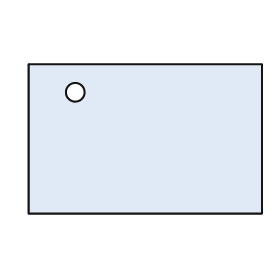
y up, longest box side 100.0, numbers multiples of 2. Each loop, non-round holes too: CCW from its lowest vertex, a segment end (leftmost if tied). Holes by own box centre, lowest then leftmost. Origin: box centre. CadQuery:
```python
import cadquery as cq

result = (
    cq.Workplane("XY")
    .moveTo(-50.0, -32.0)
    .lineTo(50.0, -32.0)
    .lineTo(50.0, 32.0)
    .lineTo(-50.0, 32.0)
    .close()
    .moveTo(-30.0, 20.0)
    .circle(4.0)
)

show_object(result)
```